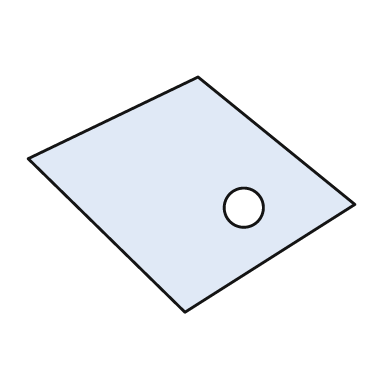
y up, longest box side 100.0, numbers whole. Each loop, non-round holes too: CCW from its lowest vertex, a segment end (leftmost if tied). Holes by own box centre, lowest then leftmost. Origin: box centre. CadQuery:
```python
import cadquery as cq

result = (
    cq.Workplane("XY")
    .moveTo(-2.0, -36.0)
    .lineTo(50.0, -3.0)
    .lineTo(2.0, 36.0)
    .lineTo(-50.0, 11.0)
    .close()
    .moveTo(16.0, -4.0)
    .circle(6.0)
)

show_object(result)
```